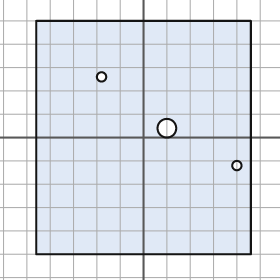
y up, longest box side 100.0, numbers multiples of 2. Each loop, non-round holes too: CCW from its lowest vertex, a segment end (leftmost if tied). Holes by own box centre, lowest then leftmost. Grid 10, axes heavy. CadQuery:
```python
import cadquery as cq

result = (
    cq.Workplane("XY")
    .moveTo(-46.0, -50.0)
    .lineTo(46.0, -50.0)
    .lineTo(46.0, 50.0)
    .lineTo(-46.0, 50.0)
    .close()
    .moveTo(40.0, -12.0)
    .circle(2.0)
    .moveTo(10.0, 4.0)
    .circle(4.0)
    .moveTo(-18.0, 26.0)
    .circle(2.0)
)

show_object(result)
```